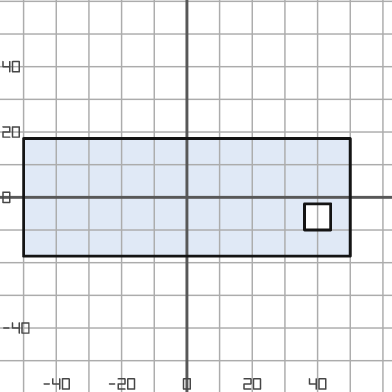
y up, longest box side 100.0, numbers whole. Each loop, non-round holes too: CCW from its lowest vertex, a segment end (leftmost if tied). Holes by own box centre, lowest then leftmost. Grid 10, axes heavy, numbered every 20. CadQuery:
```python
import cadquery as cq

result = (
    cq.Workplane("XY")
    .moveTo(-50.0, -18.0)
    .lineTo(50.0, -18.0)
    .lineTo(50.0, 18.0)
    .lineTo(-50.0, 18.0)
    .close()
    .moveTo(36.0, -10.0)
    .lineTo(44.0, -10.0)
    .lineTo(44.0, -2.0)
    .lineTo(36.0, -2.0)
    .close()
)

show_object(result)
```